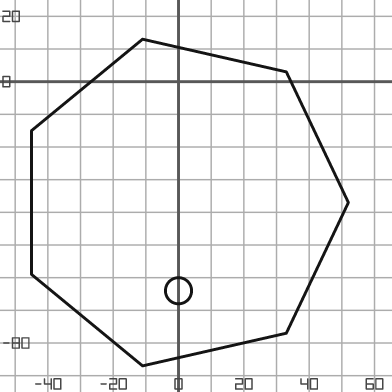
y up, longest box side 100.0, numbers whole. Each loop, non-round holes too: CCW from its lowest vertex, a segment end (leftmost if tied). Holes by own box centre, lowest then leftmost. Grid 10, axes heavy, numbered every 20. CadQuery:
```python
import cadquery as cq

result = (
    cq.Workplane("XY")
    .moveTo(-11.0, -87.0)
    .lineTo(33.0, -77.0)
    .lineTo(52.0, -37.0)
    .lineTo(33.0, 3.0)
    .lineTo(-11.0, 13.0)
    .lineTo(-45.0, -15.0)
    .lineTo(-45.0, -59.0)
    .close()
    .moveTo(0.0, -64.0)
    .circle(4.0)
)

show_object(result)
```